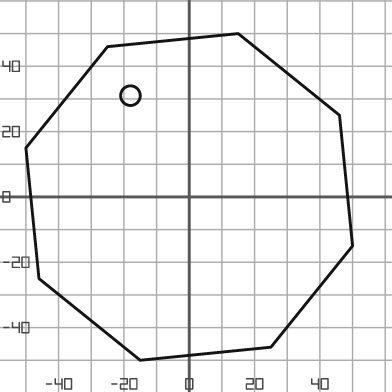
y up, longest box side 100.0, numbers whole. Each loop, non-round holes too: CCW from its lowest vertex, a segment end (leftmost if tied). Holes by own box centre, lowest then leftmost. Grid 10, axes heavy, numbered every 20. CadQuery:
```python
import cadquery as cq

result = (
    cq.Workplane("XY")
    .moveTo(-15.0, -50.0)
    .lineTo(25.0, -46.0)
    .lineTo(50.0, -15.0)
    .lineTo(46.0, 25.0)
    .lineTo(15.0, 50.0)
    .lineTo(-25.0, 46.0)
    .lineTo(-50.0, 15.0)
    .lineTo(-46.0, -25.0)
    .close()
    .moveTo(-18.0, 31.0)
    .circle(3.0)
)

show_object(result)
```